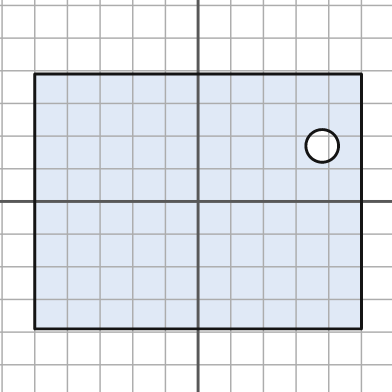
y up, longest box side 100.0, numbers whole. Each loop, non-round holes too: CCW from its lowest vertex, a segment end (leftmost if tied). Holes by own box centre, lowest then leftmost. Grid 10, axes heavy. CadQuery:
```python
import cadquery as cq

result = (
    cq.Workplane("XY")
    .moveTo(-50.0, -39.0)
    .lineTo(50.0, -39.0)
    .lineTo(50.0, 39.0)
    .lineTo(-50.0, 39.0)
    .close()
    .moveTo(38.0, 17.0)
    .circle(5.0)
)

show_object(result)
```